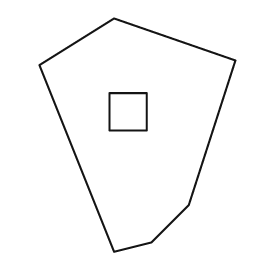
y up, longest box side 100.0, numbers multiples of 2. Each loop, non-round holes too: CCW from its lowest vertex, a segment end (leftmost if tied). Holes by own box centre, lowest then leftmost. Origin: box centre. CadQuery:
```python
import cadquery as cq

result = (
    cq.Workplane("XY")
    .moveTo(-10.0, -50.0)
    .lineTo(6.0, -46.0)
    .lineTo(22.0, -30.0)
    .lineTo(42.0, 32.0)
    .lineTo(-10.0, 50.0)
    .lineTo(-42.0, 30.0)
    .close()
    .moveTo(-12.0, 2.0)
    .lineTo(4.0, 2.0)
    .lineTo(4.0, 18.0)
    .lineTo(-12.0, 18.0)
    .close()
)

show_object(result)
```